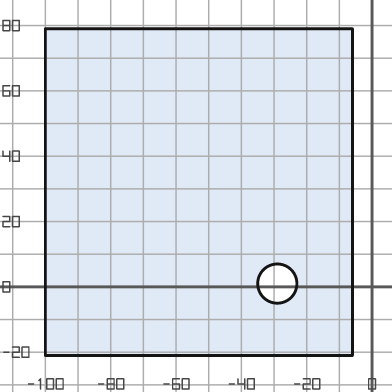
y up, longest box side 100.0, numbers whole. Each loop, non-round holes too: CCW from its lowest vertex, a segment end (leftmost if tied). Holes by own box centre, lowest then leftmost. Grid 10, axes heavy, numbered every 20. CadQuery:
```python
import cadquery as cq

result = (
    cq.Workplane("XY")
    .moveTo(-100.0, -21.0)
    .lineTo(-6.0, -21.0)
    .lineTo(-6.0, 79.0)
    .lineTo(-100.0, 79.0)
    .close()
    .moveTo(-29.0, 1.0)
    .circle(6.0)
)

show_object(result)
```